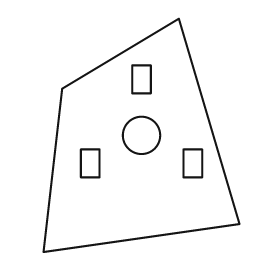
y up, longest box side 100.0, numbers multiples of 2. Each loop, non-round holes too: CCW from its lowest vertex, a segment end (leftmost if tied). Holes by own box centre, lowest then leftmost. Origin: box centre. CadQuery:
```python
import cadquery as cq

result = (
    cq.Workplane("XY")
    .moveTo(-42.0, -50.0)
    .lineTo(42.0, -38.0)
    .lineTo(16.0, 50.0)
    .lineTo(-34.0, 20.0)
    .close()
    .moveTo(-26.0, -18.0)
    .lineTo(-18.0, -18.0)
    .lineTo(-18.0, -6.0)
    .lineTo(-26.0, -6.0)
    .close()
    .moveTo(18.0, -18.0)
    .lineTo(26.0, -18.0)
    .lineTo(26.0, -6.0)
    .lineTo(18.0, -6.0)
    .close()
    .moveTo(0.0, 0.0)
    .circle(8.0)
    .moveTo(-4.0, 18.0)
    .lineTo(4.0, 18.0)
    .lineTo(4.0, 30.0)
    .lineTo(-4.0, 30.0)
    .close()
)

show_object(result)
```